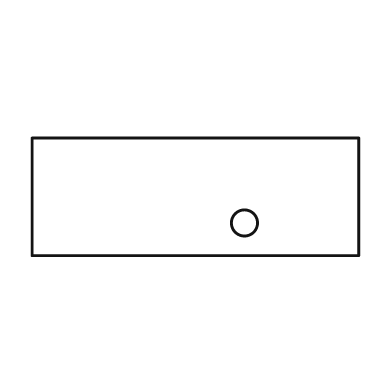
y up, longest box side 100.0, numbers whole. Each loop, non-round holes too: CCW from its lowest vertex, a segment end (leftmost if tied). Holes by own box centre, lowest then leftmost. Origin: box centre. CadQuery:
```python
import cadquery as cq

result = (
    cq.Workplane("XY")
    .moveTo(-50.0, -18.0)
    .lineTo(50.0, -18.0)
    .lineTo(50.0, 18.0)
    .lineTo(-50.0, 18.0)
    .close()
    .moveTo(15.0, -8.0)
    .circle(4.0)
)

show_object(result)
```